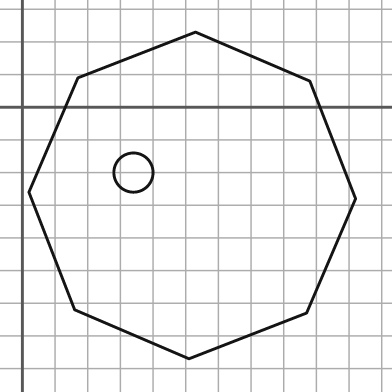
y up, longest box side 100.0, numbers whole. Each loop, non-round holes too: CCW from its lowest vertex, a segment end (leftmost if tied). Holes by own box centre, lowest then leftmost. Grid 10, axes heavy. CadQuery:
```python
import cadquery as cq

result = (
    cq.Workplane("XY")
    .moveTo(51.0, -77.0)
    .lineTo(87.0, -63.0)
    .lineTo(102.0, -28.0)
    .lineTo(88.0, 8.0)
    .lineTo(53.0, 23.0)
    .lineTo(17.0, 9.0)
    .lineTo(2.0, -26.0)
    .lineTo(16.0, -62.0)
    .close()
    .moveTo(34.0, -20.0)
    .circle(6.0)
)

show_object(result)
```